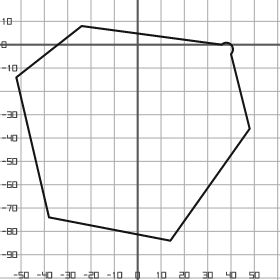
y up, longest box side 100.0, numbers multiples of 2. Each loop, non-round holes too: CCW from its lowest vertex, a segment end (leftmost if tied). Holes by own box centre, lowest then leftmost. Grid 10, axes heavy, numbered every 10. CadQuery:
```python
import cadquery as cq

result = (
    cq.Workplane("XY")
    .moveTo(14.0, -84.0)
    .lineTo(48.0, -36.0)
    .lineTo(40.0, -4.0)
    .threePointArc((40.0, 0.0), (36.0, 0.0))
    .lineTo(-24.0, 8.0)
    .lineTo(-52.0, -14.0)
    .lineTo(-38.0, -74.0)
    .close()
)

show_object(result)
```